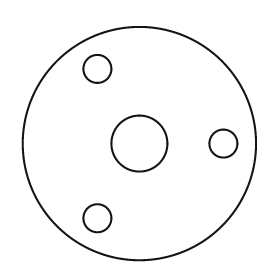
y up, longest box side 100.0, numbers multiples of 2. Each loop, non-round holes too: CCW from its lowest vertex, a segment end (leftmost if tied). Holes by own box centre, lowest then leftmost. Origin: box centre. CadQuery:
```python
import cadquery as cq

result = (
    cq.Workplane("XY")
    .moveTo(0.0, 0.0)
    .circle(50.0)
    .moveTo(-18.0, -32.0)
    .circle(6.0)
    .moveTo(0.0, 0.0)
    .circle(12.0)
    .moveTo(36.0, 0.0)
    .circle(6.0)
    .moveTo(-18.0, 32.0)
    .circle(6.0)
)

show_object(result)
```